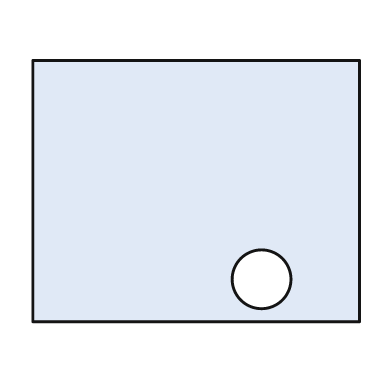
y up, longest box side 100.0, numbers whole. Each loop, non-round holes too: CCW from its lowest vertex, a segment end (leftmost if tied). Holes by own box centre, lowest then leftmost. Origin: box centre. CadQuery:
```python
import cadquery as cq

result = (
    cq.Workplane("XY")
    .moveTo(-50.0, -40.0)
    .lineTo(50.0, -40.0)
    .lineTo(50.0, 40.0)
    .lineTo(-50.0, 40.0)
    .close()
    .moveTo(20.0, -27.0)
    .circle(9.0)
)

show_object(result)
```